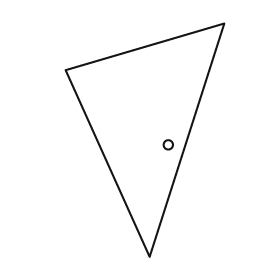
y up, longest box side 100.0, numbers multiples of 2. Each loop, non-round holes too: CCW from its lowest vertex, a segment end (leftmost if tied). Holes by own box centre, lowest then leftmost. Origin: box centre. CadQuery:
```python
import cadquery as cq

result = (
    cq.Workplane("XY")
    .moveTo(2.0, -50.0)
    .lineTo(34.0, 50.0)
    .lineTo(-34.0, 30.0)
    .close()
    .moveTo(10.0, -2.0)
    .circle(2.0)
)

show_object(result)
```